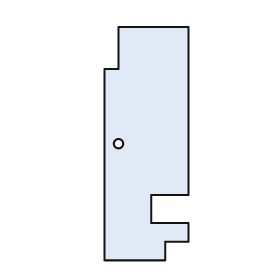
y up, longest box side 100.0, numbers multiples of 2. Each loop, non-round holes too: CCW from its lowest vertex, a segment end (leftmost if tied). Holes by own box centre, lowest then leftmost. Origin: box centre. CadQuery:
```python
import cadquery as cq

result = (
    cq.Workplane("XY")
    .moveTo(-18.0, -50.0)
    .lineTo(8.0, -50.0)
    .lineTo(8.0, -42.0)
    .lineTo(18.0, -42.0)
    .lineTo(18.0, -34.0)
    .lineTo(2.0, -34.0)
    .lineTo(2.0, -22.0)
    .lineTo(18.0, -22.0)
    .lineTo(18.0, 50.0)
    .lineTo(-12.0, 50.0)
    .lineTo(-12.0, 32.0)
    .lineTo(-18.0, 32.0)
    .close()
    .moveTo(-12.0, 0.0)
    .circle(2.0)
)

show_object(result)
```